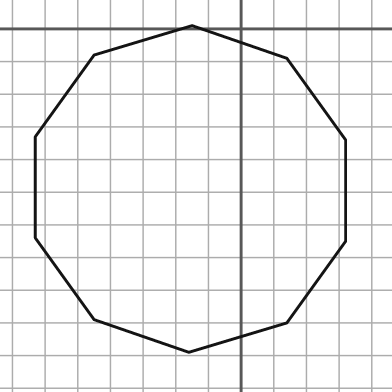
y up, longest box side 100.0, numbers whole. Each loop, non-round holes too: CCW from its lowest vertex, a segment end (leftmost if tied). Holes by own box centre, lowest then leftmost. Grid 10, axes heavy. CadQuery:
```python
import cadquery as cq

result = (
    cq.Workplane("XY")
    .moveTo(-16.0, -99.0)
    .lineTo(14.0, -90.0)
    .lineTo(32.0, -65.0)
    .lineTo(32.0, -34.0)
    .lineTo(14.0, -9.0)
    .lineTo(-15.0, 1.0)
    .lineTo(-45.0, -8.0)
    .lineTo(-63.0, -33.0)
    .lineTo(-63.0, -64.0)
    .lineTo(-45.0, -89.0)
    .close()
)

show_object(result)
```